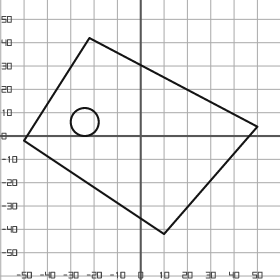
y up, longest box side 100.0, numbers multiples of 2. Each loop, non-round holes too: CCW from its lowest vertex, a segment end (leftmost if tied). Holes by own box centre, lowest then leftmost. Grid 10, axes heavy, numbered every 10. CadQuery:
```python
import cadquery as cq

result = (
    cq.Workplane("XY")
    .moveTo(10.0, -42.0)
    .lineTo(50.0, 4.0)
    .lineTo(-22.0, 42.0)
    .lineTo(-50.0, -2.0)
    .close()
    .moveTo(-24.0, 6.0)
    .circle(6.0)
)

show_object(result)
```